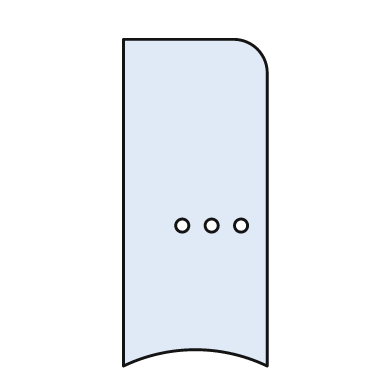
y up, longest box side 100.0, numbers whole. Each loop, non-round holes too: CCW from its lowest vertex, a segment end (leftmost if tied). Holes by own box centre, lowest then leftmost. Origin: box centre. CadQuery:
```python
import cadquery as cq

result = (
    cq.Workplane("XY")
    .moveTo(-22.0, -50.0)
    .threePointArc((0.0, -45.0), (22.0, -50.0))
    .lineTo(22.0, 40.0)
    .threePointArc((19.0, 47.0), (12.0, 50.0))
    .lineTo(-22.0, 50.0)
    .close()
    .moveTo(-4.0, -7.0)
    .circle(2.0)
    .moveTo(5.0, -7.0)
    .circle(2.0)
    .moveTo(14.0, -7.0)
    .circle(2.0)
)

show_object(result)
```